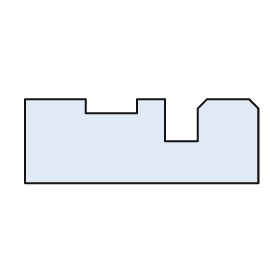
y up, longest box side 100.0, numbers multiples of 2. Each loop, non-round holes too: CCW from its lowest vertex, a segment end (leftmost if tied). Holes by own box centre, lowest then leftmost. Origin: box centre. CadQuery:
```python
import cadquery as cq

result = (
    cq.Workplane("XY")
    .moveTo(-50.0, -18.0)
    .lineTo(50.0, -18.0)
    .lineTo(50.0, 14.0)
    .lineTo(46.0, 18.0)
    .lineTo(28.0, 18.0)
    .lineTo(24.0, 14.0)
    .lineTo(24.0, 0.0)
    .lineTo(10.0, 0.0)
    .lineTo(10.0, 18.0)
    .lineTo(-2.0, 18.0)
    .lineTo(-2.0, 12.0)
    .lineTo(-24.0, 12.0)
    .lineTo(-24.0, 18.0)
    .lineTo(-50.0, 18.0)
    .close()
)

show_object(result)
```